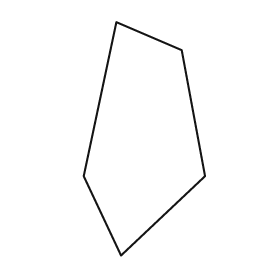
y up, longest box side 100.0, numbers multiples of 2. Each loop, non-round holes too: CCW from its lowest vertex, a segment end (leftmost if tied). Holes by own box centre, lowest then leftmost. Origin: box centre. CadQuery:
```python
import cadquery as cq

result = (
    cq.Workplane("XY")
    .moveTo(-10.0, -50.0)
    .lineTo(26.0, -16.0)
    .lineTo(16.0, 38.0)
    .lineTo(-12.0, 50.0)
    .lineTo(-26.0, -16.0)
    .close()
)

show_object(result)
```